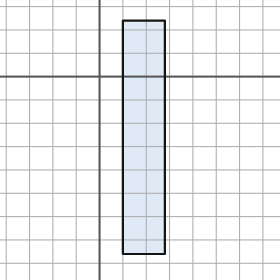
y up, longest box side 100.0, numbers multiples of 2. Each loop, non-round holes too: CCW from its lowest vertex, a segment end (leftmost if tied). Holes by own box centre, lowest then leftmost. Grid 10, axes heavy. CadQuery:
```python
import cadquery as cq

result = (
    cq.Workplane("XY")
    .moveTo(10.0, -76.0)
    .lineTo(28.0, -76.0)
    .lineTo(28.0, 24.0)
    .lineTo(10.0, 24.0)
    .close()
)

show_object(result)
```